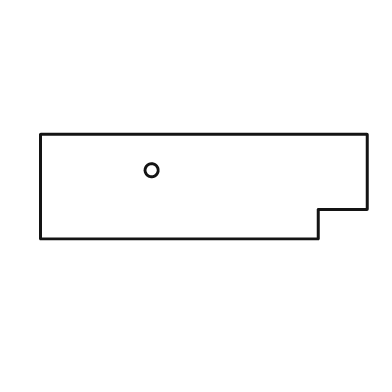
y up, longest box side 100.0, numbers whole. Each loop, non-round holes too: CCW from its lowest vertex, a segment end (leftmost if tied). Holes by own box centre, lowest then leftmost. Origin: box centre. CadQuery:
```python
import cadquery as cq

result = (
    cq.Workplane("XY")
    .moveTo(-50.0, -16.0)
    .lineTo(35.0, -16.0)
    .lineTo(35.0, -7.0)
    .lineTo(50.0, -7.0)
    .lineTo(50.0, 16.0)
    .lineTo(-50.0, 16.0)
    .close()
    .moveTo(-16.0, 5.0)
    .circle(2.0)
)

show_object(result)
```